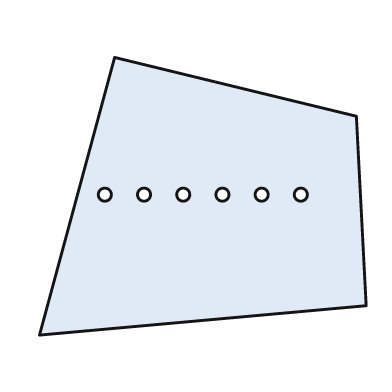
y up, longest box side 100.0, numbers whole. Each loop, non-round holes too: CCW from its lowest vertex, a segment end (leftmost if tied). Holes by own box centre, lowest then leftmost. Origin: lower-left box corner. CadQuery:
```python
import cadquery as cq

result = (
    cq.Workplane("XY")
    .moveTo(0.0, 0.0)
    .lineTo(100.0, 9.0)
    .lineTo(97.0, 67.0)
    .lineTo(23.0, 85.0)
    .close()
    .moveTo(20.0, 43.0)
    .circle(2.0)
    .moveTo(32.0, 43.0)
    .circle(2.0)
    .moveTo(44.0, 43.0)
    .circle(2.0)
    .moveTo(56.0, 43.0)
    .circle(2.0)
    .moveTo(68.0, 43.0)
    .circle(2.0)
    .moveTo(80.0, 43.0)
    .circle(2.0)
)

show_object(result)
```